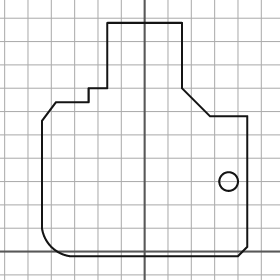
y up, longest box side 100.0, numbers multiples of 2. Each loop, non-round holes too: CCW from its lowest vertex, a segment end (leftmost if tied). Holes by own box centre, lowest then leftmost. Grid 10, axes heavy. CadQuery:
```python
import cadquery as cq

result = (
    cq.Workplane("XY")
    .moveTo(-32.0, -2.0)
    .lineTo(40.0, -2.0)
    .lineTo(44.0, 2.0)
    .lineTo(44.0, 58.0)
    .lineTo(28.0, 58.0)
    .lineTo(16.0, 70.0)
    .lineTo(16.0, 98.0)
    .lineTo(-16.0, 98.0)
    .lineTo(-16.0, 70.0)
    .lineTo(-24.0, 70.0)
    .lineTo(-24.0, 64.0)
    .lineTo(-38.0, 64.0)
    .lineTo(-44.0, 56.0)
    .lineTo(-44.0, 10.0)
    .threePointArc((-40.0, 2.0), (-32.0, -2.0))
    .close()
    .moveTo(36.0, 30.0)
    .circle(4.0)
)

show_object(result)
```